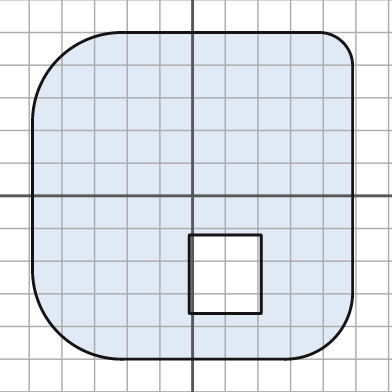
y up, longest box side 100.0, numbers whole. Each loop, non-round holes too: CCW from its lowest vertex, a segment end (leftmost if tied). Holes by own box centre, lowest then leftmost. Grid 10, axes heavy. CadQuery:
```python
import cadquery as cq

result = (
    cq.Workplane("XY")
    .moveTo(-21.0, -50.0)
    .lineTo(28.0, -50.0)
    .threePointArc((43.0, -44.0), (49.0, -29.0))
    .lineTo(49.0, 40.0)
    .threePointArc((46.0, 47.0), (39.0, 50.0))
    .lineTo(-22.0, 50.0)
    .threePointArc((-41.0, 42.0), (-49.0, 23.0))
    .lineTo(-49.0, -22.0)
    .threePointArc((-41.0, -42.0), (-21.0, -50.0))
    .close()
    .moveTo(-1.0, -36.0)
    .lineTo(21.0, -36.0)
    .lineTo(21.0, -12.0)
    .lineTo(-1.0, -12.0)
    .close()
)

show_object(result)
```